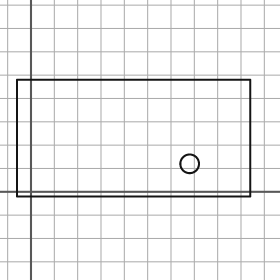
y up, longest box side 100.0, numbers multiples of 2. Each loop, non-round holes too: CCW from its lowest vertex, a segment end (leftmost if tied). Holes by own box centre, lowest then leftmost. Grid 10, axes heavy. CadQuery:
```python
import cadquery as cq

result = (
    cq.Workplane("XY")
    .moveTo(-6.0, -2.0)
    .lineTo(94.0, -2.0)
    .lineTo(94.0, 48.0)
    .lineTo(-6.0, 48.0)
    .close()
    .moveTo(68.0, 12.0)
    .circle(4.0)
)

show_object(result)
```